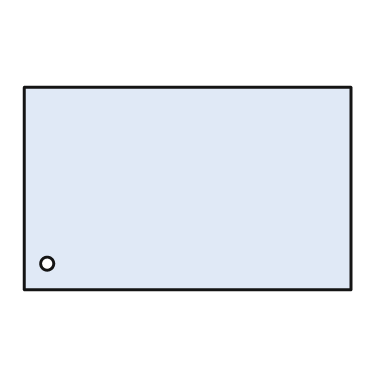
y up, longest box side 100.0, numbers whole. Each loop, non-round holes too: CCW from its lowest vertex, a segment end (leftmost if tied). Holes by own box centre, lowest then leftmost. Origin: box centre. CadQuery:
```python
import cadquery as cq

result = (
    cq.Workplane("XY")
    .moveTo(-50.0, -31.0)
    .lineTo(50.0, -31.0)
    .lineTo(50.0, 31.0)
    .lineTo(-50.0, 31.0)
    .close()
    .moveTo(-43.0, -23.0)
    .circle(2.0)
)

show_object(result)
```